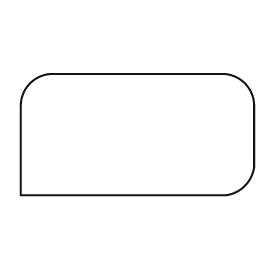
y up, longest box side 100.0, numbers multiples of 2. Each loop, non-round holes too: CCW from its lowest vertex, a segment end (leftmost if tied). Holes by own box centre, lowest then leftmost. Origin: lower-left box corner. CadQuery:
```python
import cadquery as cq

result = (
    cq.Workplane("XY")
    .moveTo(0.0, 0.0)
    .lineTo(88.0, 0.0)
    .threePointArc((96.0, 4.0), (100.0, 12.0))
    .lineTo(100.0, 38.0)
    .threePointArc((96.0, 48.0), (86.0, 52.0))
    .lineTo(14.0, 52.0)
    .threePointArc((4.0, 48.0), (0.0, 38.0))
    .close()
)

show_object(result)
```